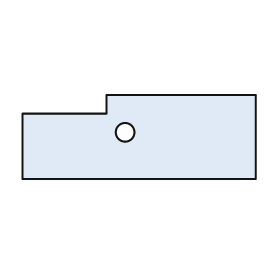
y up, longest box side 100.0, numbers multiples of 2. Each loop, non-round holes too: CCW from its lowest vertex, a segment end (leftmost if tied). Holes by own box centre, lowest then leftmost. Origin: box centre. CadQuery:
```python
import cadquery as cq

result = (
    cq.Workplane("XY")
    .moveTo(-50.0, -18.0)
    .lineTo(50.0, -18.0)
    .lineTo(50.0, 18.0)
    .lineTo(-14.0, 18.0)
    .lineTo(-14.0, 10.0)
    .lineTo(-50.0, 10.0)
    .close()
    .moveTo(-6.0, 2.0)
    .circle(4.0)
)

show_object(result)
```